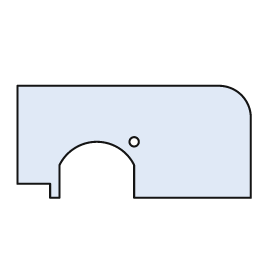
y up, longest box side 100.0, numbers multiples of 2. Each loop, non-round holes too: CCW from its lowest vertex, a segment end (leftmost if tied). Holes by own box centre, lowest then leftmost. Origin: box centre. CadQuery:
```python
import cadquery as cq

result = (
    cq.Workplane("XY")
    .moveTo(-36.0, -24.0)
    .lineTo(-32.0, -24.0)
    .lineTo(-32.0, -10.0)
    .threePointArc((-16.0, 0.0), (0.0, -10.0))
    .lineTo(0.0, -24.0)
    .lineTo(50.0, -24.0)
    .lineTo(50.0, 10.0)
    .threePointArc((46.0, 20.0), (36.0, 24.0))
    .lineTo(-50.0, 24.0)
    .lineTo(-50.0, -18.0)
    .lineTo(-36.0, -18.0)
    .close()
    .moveTo(0.0, 0.0)
    .circle(2.0)
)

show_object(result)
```